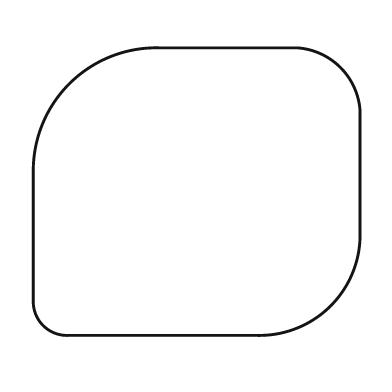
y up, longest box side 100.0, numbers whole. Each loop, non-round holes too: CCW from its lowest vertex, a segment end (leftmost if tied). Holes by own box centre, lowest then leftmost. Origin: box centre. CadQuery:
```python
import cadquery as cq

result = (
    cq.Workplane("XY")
    .moveTo(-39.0, -44.0)
    .lineTo(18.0, -44.0)
    .threePointArc((41.0, -35.0), (50.0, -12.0))
    .lineTo(50.0, 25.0)
    .threePointArc((44.0, 38.0), (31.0, 44.0))
    .lineTo(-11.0, 44.0)
    .threePointArc((-39.0, 33.0), (-50.0, 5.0))
    .lineTo(-50.0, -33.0)
    .threePointArc((-47.0, -41.0), (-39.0, -44.0))
    .close()
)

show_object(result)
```